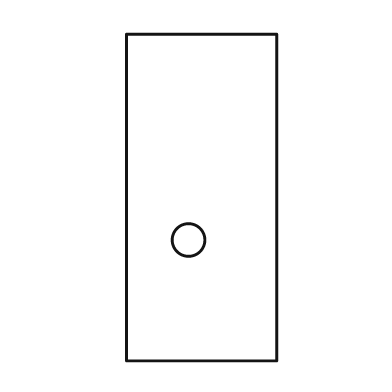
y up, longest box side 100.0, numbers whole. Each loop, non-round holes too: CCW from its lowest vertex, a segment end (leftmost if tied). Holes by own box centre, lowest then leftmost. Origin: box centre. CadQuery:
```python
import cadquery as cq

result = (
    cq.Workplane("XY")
    .moveTo(-23.0, -50.0)
    .lineTo(23.0, -50.0)
    .lineTo(23.0, 50.0)
    .lineTo(-23.0, 50.0)
    .close()
    .moveTo(-4.0, -13.0)
    .circle(5.0)
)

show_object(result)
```